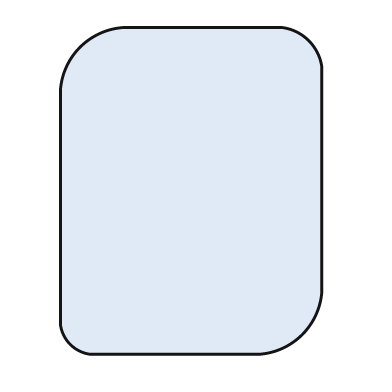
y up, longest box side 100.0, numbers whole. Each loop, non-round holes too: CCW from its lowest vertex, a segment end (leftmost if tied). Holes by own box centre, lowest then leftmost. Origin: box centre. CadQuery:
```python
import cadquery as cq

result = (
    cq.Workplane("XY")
    .moveTo(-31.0, -50.0)
    .lineTo(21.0, -50.0)
    .threePointArc((34.0, -44.0), (40.0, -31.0))
    .lineTo(40.0, 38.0)
    .threePointArc((36.0, 46.0), (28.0, 50.0))
    .lineTo(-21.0, 50.0)
    .threePointArc((-34.0, 44.0), (-40.0, 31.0))
    .lineTo(-40.0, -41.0)
    .threePointArc((-37.0, -47.0), (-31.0, -50.0))
    .close()
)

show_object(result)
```